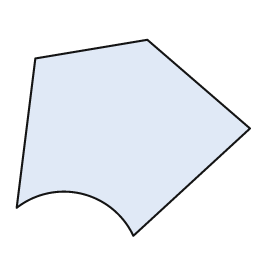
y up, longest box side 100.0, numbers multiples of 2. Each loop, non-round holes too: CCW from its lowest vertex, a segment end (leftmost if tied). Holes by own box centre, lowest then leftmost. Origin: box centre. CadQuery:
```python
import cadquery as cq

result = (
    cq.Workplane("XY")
    .moveTo(0.0, -42.0)
    .lineTo(50.0, 4.0)
    .lineTo(6.0, 42.0)
    .lineTo(-42.0, 34.0)
    .lineTo(-50.0, -30.0)
    .threePointArc((-22.0, -24.0), (0.0, -42.0))
    .close()
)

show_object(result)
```